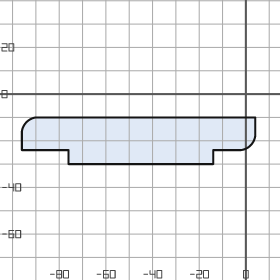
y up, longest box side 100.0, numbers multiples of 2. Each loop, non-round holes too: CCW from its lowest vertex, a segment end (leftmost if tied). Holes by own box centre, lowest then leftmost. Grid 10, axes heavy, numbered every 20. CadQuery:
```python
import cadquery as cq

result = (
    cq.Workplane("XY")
    .moveTo(-76.0, -30.0)
    .lineTo(-14.0, -30.0)
    .lineTo(-14.0, -24.0)
    .lineTo(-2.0, -24.0)
    .threePointArc((2.0, -22.0), (4.0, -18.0))
    .lineTo(4.0, -10.0)
    .lineTo(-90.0, -10.0)
    .threePointArc((-94.0, -12.0), (-96.0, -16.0))
    .lineTo(-96.0, -24.0)
    .lineTo(-76.0, -24.0)
    .close()
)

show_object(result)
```